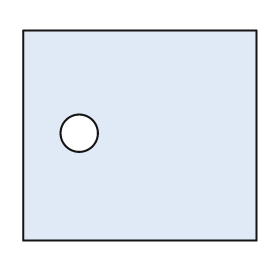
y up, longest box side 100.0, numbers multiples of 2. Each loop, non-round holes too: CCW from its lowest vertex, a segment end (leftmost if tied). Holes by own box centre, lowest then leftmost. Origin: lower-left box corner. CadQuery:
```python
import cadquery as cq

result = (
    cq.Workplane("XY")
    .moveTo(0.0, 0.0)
    .lineTo(100.0, 0.0)
    .lineTo(100.0, 90.0)
    .lineTo(0.0, 90.0)
    .close()
    .moveTo(24.0, 46.0)
    .circle(8.0)
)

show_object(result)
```